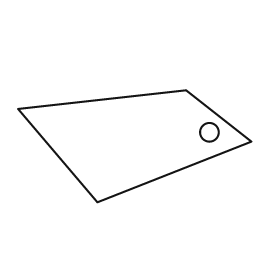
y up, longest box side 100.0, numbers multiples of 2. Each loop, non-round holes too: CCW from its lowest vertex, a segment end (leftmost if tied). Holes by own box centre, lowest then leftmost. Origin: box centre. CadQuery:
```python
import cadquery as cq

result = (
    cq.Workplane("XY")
    .moveTo(-16.0, -24.0)
    .lineTo(50.0, 2.0)
    .lineTo(22.0, 24.0)
    .lineTo(-50.0, 16.0)
    .close()
    .moveTo(32.0, 6.0)
    .circle(4.0)
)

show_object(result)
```